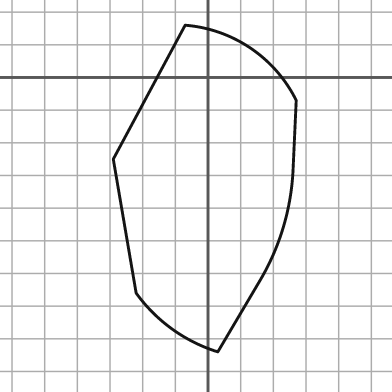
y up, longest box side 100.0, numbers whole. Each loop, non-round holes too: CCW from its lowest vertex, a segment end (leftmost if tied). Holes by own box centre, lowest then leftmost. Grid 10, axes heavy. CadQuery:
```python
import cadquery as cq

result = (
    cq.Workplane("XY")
    .moveTo(3.0, -84.0)
    .lineTo(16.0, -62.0)
    .threePointArc((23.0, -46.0), (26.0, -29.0))
    .lineTo(27.0, -7.0)
    .threePointArc((13.0, 9.0), (-7.0, 16.0))
    .lineTo(-29.0, -25.0)
    .lineTo(-22.0, -66.0)
    .threePointArc((-11.0, -77.0), (3.0, -84.0))
    .close()
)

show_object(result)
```